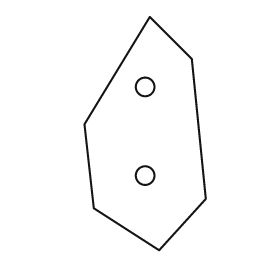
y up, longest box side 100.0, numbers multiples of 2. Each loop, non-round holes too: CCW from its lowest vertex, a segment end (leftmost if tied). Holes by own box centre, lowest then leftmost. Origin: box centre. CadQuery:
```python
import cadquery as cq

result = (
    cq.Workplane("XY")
    .moveTo(6.0, -50.0)
    .lineTo(26.0, -28.0)
    .lineTo(20.0, 32.0)
    .lineTo(2.0, 50.0)
    .lineTo(-26.0, 4.0)
    .lineTo(-22.0, -32.0)
    .close()
    .moveTo(0.0, -18.0)
    .circle(4.0)
    .moveTo(0.0, 20.0)
    .circle(4.0)
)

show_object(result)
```